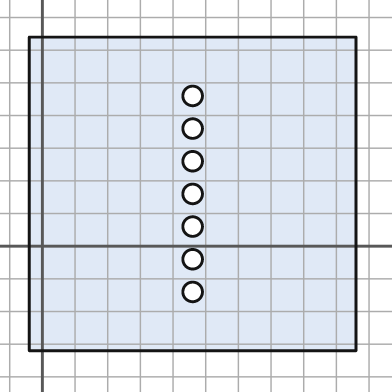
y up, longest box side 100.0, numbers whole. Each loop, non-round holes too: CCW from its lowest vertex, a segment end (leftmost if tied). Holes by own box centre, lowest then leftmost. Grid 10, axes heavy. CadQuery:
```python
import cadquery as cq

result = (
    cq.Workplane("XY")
    .moveTo(-4.0, -32.0)
    .lineTo(96.0, -32.0)
    .lineTo(96.0, 64.0)
    .lineTo(-4.0, 64.0)
    .close()
    .moveTo(46.0, -14.0)
    .circle(3.0)
    .moveTo(46.0, -4.0)
    .circle(3.0)
    .moveTo(46.0, 6.0)
    .circle(3.0)
    .moveTo(46.0, 16.0)
    .circle(3.0)
    .moveTo(46.0, 26.0)
    .circle(3.0)
    .moveTo(46.0, 36.0)
    .circle(3.0)
    .moveTo(46.0, 46.0)
    .circle(3.0)
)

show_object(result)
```